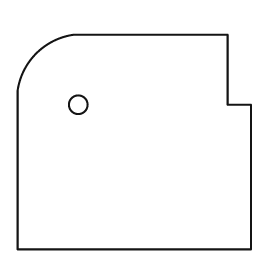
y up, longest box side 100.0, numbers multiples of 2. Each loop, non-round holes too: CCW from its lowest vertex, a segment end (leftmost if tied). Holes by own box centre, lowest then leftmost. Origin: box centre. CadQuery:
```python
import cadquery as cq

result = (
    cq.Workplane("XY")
    .moveTo(-50.0, -46.0)
    .lineTo(50.0, -46.0)
    .lineTo(50.0, 16.0)
    .lineTo(40.0, 16.0)
    .lineTo(40.0, 46.0)
    .lineTo(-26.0, 46.0)
    .threePointArc((-42.0, 38.0), (-50.0, 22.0))
    .close()
    .moveTo(-24.0, 16.0)
    .circle(4.0)
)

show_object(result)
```